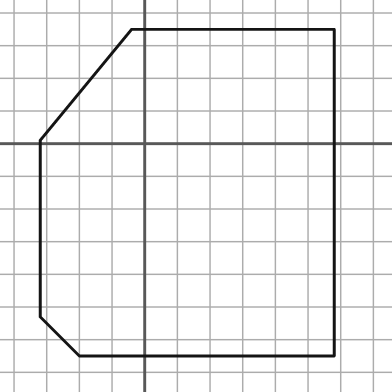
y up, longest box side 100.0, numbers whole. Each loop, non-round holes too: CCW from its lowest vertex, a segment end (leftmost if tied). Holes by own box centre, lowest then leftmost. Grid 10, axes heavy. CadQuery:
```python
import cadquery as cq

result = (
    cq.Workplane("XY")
    .moveTo(-20.0, -65.0)
    .lineTo(58.0, -65.0)
    .lineTo(58.0, 35.0)
    .lineTo(-4.0, 35.0)
    .lineTo(-32.0, 1.0)
    .lineTo(-32.0, -53.0)
    .close()
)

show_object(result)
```